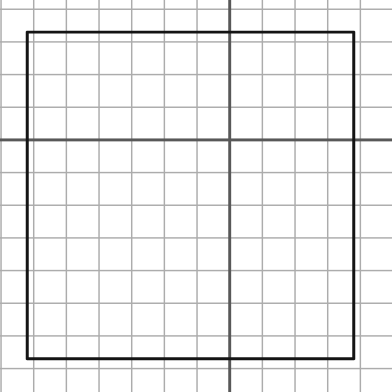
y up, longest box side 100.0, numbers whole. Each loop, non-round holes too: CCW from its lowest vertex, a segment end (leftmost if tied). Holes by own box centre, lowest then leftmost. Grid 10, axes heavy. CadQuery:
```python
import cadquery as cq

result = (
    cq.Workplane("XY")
    .moveTo(-62.0, -67.0)
    .lineTo(38.0, -67.0)
    .lineTo(38.0, 33.0)
    .lineTo(-62.0, 33.0)
    .close()
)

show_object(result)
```